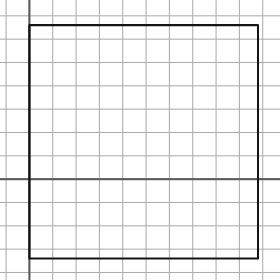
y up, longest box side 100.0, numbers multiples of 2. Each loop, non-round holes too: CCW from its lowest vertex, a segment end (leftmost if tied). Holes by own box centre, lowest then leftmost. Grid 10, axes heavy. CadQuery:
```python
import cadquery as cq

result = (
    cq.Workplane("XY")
    .moveTo(0.0, -34.0)
    .lineTo(98.0, -34.0)
    .lineTo(98.0, 66.0)
    .lineTo(0.0, 66.0)
    .close()
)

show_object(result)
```